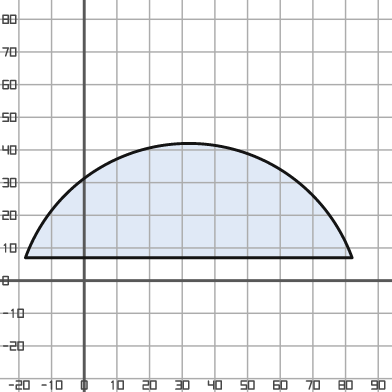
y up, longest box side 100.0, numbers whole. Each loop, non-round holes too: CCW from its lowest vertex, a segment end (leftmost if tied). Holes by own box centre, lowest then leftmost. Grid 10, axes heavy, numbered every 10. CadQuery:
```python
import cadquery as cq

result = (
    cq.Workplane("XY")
    .moveTo(-18.0, 7.0)
    .lineTo(82.0, 7.0)
    .threePointArc((32.0, 42.0), (-18.0, 7.0))
    .close()
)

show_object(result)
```